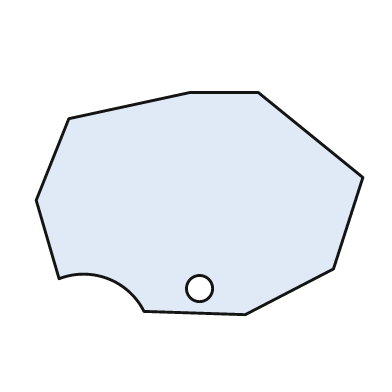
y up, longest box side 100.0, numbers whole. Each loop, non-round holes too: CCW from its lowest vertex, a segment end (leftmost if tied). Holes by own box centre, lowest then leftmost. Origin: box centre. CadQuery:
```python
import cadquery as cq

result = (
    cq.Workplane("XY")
    .moveTo(14.0, -34.0)
    .lineTo(41.0, -20.0)
    .lineTo(50.0, 8.0)
    .lineTo(18.0, 34.0)
    .lineTo(-3.0, 34.0)
    .lineTo(-40.0, 26.0)
    .lineTo(-50.0, 1.0)
    .lineTo(-43.0, -23.0)
    .threePointArc((-28.0, -23.0), (-17.0, -33.0))
    .close()
    .moveTo(0.0, -26.0)
    .circle(4.0)
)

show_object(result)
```